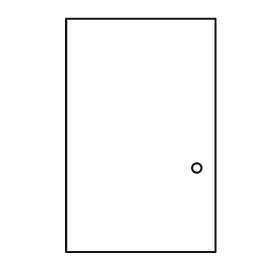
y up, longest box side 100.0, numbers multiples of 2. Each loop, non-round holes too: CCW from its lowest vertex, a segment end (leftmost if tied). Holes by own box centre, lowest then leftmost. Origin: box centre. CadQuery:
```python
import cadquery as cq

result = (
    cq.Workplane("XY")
    .moveTo(-32.0, -50.0)
    .lineTo(32.0, -50.0)
    .lineTo(32.0, 50.0)
    .lineTo(-32.0, 50.0)
    .close()
    .moveTo(24.0, -14.0)
    .circle(2.0)
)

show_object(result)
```